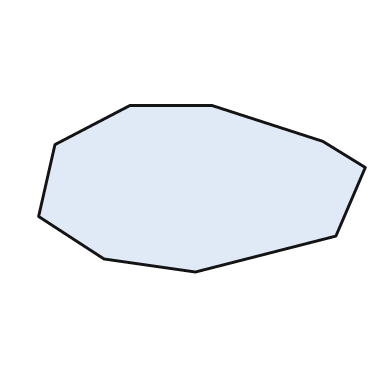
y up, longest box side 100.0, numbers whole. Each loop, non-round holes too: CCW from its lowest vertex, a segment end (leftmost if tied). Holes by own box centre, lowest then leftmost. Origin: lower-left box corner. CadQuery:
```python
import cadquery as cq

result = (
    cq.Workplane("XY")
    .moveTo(48.0, 0.0)
    .lineTo(91.0, 11.0)
    .lineTo(100.0, 32.0)
    .lineTo(87.0, 40.0)
    .lineTo(53.0, 51.0)
    .lineTo(28.0, 51.0)
    .lineTo(5.0, 39.0)
    .lineTo(0.0, 17.0)
    .lineTo(20.0, 4.0)
    .close()
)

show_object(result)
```